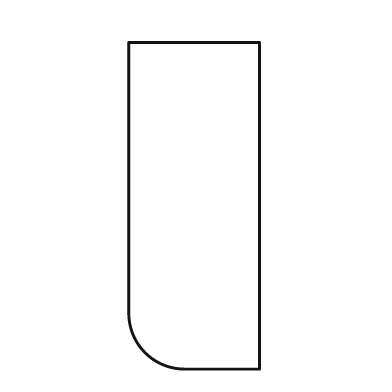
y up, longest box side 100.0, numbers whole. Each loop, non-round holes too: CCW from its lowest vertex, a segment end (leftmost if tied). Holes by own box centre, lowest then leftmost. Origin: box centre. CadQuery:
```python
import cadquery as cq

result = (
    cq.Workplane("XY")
    .moveTo(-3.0, -50.0)
    .lineTo(20.0, -50.0)
    .lineTo(20.0, 50.0)
    .lineTo(-20.0, 50.0)
    .lineTo(-20.0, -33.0)
    .threePointArc((-15.0, -45.0), (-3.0, -50.0))
    .close()
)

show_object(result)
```